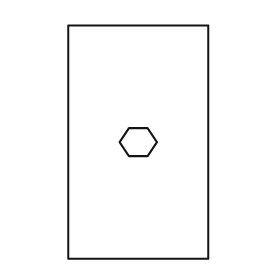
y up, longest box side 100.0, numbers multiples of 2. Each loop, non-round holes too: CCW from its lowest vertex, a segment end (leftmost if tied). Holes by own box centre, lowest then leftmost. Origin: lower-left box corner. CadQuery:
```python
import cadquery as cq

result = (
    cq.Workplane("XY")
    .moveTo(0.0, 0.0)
    .lineTo(60.0, 0.0)
    .lineTo(60.0, 100.0)
    .lineTo(0.0, 100.0)
    .close()
    .moveTo(26.0, 44.0)
    .lineTo(34.0, 44.0)
    .lineTo(38.0, 50.0)
    .lineTo(34.0, 56.0)
    .lineTo(26.0, 56.0)
    .lineTo(22.0, 50.0)
    .close()
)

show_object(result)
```